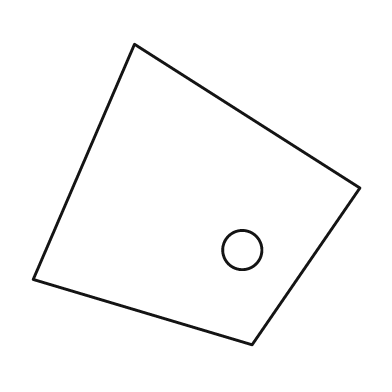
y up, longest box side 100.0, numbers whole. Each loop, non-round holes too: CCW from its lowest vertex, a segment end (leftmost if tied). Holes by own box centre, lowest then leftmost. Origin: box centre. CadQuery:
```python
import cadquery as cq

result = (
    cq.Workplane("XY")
    .moveTo(17.0, -46.0)
    .lineTo(50.0, 2.0)
    .lineTo(-19.0, 46.0)
    .lineTo(-50.0, -26.0)
    .close()
    .moveTo(14.0, -17.0)
    .circle(6.0)
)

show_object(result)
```